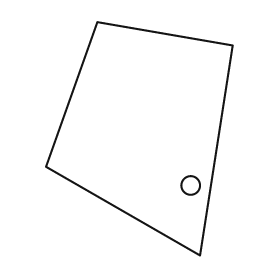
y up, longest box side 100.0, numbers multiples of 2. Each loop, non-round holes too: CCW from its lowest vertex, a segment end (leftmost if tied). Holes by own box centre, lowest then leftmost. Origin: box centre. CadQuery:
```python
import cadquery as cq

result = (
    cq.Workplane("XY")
    .moveTo(26.0, -50.0)
    .lineTo(40.0, 40.0)
    .lineTo(-18.0, 50.0)
    .lineTo(-40.0, -12.0)
    .close()
    .moveTo(22.0, -20.0)
    .circle(4.0)
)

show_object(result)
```